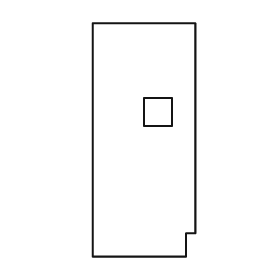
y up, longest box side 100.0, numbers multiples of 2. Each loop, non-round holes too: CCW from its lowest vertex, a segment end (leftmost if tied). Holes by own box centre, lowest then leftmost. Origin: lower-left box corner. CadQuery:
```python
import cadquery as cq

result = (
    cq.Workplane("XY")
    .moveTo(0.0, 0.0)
    .lineTo(40.0, 0.0)
    .lineTo(40.0, 10.0)
    .lineTo(44.0, 10.0)
    .lineTo(44.0, 100.0)
    .lineTo(0.0, 100.0)
    .close()
    .moveTo(22.0, 56.0)
    .lineTo(34.0, 56.0)
    .lineTo(34.0, 68.0)
    .lineTo(22.0, 68.0)
    .close()
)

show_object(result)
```